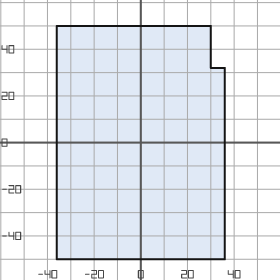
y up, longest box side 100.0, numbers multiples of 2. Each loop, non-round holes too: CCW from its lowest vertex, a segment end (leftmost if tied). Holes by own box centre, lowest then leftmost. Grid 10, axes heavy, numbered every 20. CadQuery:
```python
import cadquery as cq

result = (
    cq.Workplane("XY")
    .moveTo(-36.0, -50.0)
    .lineTo(36.0, -50.0)
    .lineTo(36.0, 32.0)
    .lineTo(30.0, 32.0)
    .lineTo(30.0, 50.0)
    .lineTo(-36.0, 50.0)
    .close()
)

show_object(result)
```